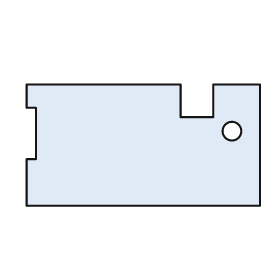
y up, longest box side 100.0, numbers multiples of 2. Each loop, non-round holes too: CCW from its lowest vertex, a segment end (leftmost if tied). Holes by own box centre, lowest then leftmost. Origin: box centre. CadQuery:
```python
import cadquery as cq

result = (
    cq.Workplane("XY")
    .moveTo(-50.0, -26.0)
    .lineTo(50.0, -26.0)
    .lineTo(50.0, 26.0)
    .lineTo(30.0, 26.0)
    .lineTo(30.0, 12.0)
    .lineTo(16.0, 12.0)
    .lineTo(16.0, 26.0)
    .lineTo(-50.0, 26.0)
    .lineTo(-50.0, 16.0)
    .lineTo(-46.0, 16.0)
    .lineTo(-46.0, -6.0)
    .lineTo(-50.0, -6.0)
    .close()
    .moveTo(38.0, 6.0)
    .circle(4.0)
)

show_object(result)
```